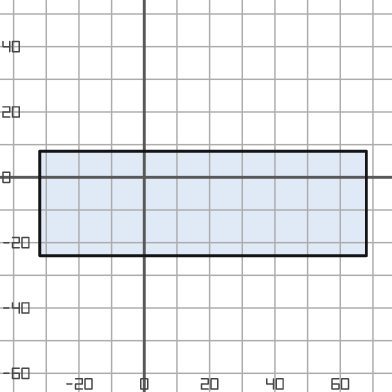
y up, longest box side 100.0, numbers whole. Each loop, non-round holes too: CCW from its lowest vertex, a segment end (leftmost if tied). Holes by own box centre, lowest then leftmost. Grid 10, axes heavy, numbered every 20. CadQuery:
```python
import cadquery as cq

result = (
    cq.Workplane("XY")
    .moveTo(-32.0, -24.0)
    .lineTo(68.0, -24.0)
    .lineTo(68.0, 8.0)
    .lineTo(-32.0, 8.0)
    .close()
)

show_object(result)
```